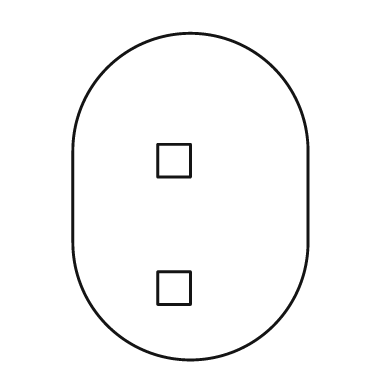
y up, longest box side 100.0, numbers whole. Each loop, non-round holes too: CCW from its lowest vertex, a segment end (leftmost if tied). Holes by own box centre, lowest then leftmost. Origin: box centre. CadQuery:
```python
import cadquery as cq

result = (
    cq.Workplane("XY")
    .moveTo(-36.0, -14.0)
    .threePointArc((0.0, -50.0), (36.0, -14.0))
    .lineTo(36.0, 14.0)
    .threePointArc((0.0, 50.0), (-36.0, 14.0))
    .close()
    .moveTo(-10.0, -33.0)
    .lineTo(0.0, -33.0)
    .lineTo(0.0, -23.0)
    .lineTo(-10.0, -23.0)
    .close()
    .moveTo(-10.0, 6.0)
    .lineTo(0.0, 6.0)
    .lineTo(0.0, 16.0)
    .lineTo(-10.0, 16.0)
    .close()
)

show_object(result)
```